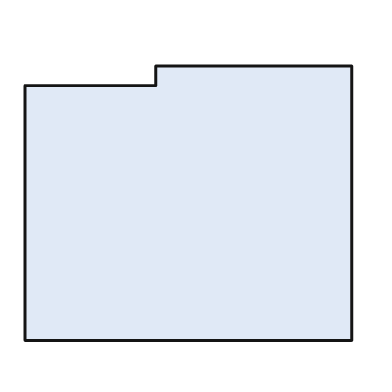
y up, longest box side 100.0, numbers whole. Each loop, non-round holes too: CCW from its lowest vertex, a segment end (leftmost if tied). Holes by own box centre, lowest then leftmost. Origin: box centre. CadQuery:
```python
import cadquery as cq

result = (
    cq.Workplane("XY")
    .moveTo(-50.0, -42.0)
    .lineTo(50.0, -42.0)
    .lineTo(50.0, 42.0)
    .lineTo(-10.0, 42.0)
    .lineTo(-10.0, 36.0)
    .lineTo(-50.0, 36.0)
    .close()
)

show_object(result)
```